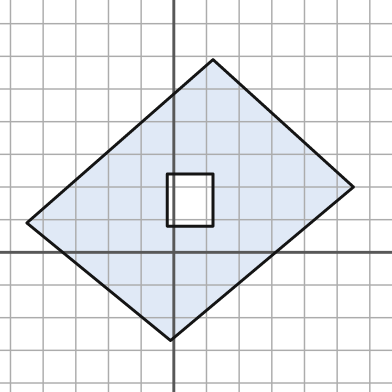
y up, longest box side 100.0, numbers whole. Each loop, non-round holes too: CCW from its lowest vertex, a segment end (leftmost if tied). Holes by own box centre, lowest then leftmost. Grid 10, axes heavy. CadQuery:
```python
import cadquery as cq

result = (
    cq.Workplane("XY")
    .moveTo(-1.0, -27.0)
    .lineTo(55.0, 20.0)
    .lineTo(12.0, 59.0)
    .lineTo(-45.0, 9.0)
    .close()
    .moveTo(-2.0, 8.0)
    .lineTo(12.0, 8.0)
    .lineTo(12.0, 24.0)
    .lineTo(-2.0, 24.0)
    .close()
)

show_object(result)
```